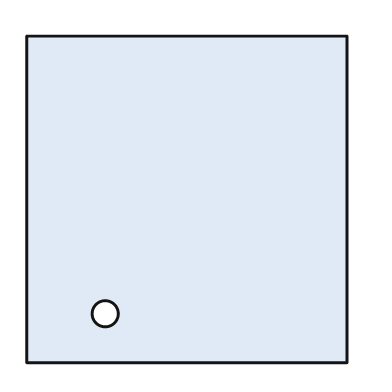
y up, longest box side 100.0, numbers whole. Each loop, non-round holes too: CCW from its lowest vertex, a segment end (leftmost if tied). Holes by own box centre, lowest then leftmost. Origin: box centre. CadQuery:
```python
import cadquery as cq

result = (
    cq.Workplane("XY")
    .moveTo(-49.0, -50.0)
    .lineTo(49.0, -50.0)
    .lineTo(49.0, 50.0)
    .lineTo(-49.0, 50.0)
    .close()
    .moveTo(-25.0, -35.0)
    .circle(4.0)
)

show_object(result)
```